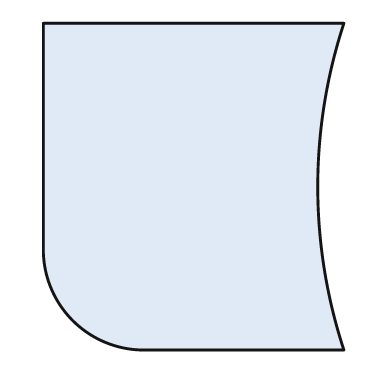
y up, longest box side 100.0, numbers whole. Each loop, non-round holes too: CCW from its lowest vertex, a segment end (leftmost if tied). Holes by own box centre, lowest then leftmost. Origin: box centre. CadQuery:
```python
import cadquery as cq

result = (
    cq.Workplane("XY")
    .moveTo(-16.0, -50.0)
    .lineTo(46.0, -50.0)
    .threePointArc((38.0, 0.0), (46.0, 50.0))
    .lineTo(-46.0, 50.0)
    .lineTo(-46.0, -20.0)
    .threePointArc((-37.0, -41.0), (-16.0, -50.0))
    .close()
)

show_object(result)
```